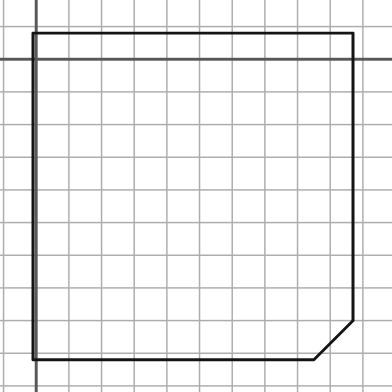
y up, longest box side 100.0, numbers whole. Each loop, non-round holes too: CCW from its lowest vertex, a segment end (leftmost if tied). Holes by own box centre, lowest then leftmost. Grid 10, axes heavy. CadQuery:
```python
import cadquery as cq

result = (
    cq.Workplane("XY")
    .moveTo(-1.0, -92.0)
    .lineTo(85.0, -92.0)
    .lineTo(97.0, -80.0)
    .lineTo(97.0, 8.0)
    .lineTo(-1.0, 8.0)
    .close()
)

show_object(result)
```